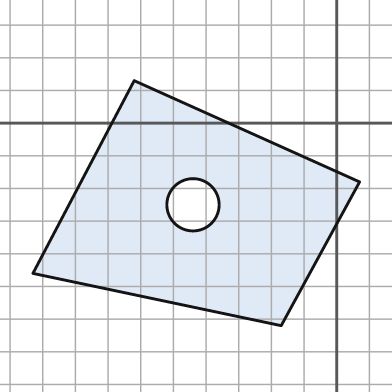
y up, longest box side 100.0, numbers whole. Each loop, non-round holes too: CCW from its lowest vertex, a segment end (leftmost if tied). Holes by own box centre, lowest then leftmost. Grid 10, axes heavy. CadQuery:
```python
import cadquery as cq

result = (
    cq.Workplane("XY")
    .moveTo(-17.0, -62.0)
    .lineTo(7.0, -18.0)
    .lineTo(-62.0, 13.0)
    .lineTo(-93.0, -46.0)
    .close()
    .moveTo(-44.0, -25.0)
    .circle(8.0)
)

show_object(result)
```